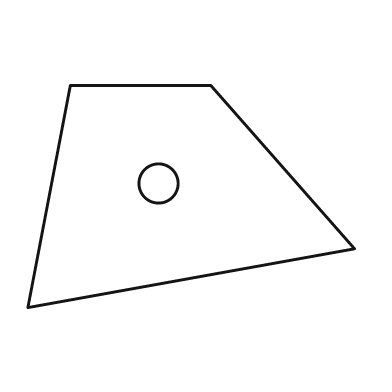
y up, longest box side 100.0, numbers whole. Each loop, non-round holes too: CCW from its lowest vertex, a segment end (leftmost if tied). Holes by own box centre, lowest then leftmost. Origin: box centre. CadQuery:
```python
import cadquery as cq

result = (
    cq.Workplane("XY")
    .moveTo(-50.0, -34.0)
    .lineTo(50.0, -16.0)
    .lineTo(6.0, 34.0)
    .lineTo(-37.0, 34.0)
    .close()
    .moveTo(-10.0, 4.0)
    .circle(6.0)
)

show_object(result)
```